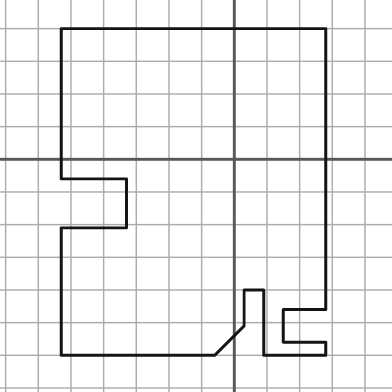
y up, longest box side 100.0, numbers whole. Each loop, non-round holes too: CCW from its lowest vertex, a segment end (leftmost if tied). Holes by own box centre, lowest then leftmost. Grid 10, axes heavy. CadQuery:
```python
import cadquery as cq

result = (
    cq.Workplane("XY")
    .moveTo(-53.0, -60.0)
    .lineTo(-6.0, -60.0)
    .lineTo(3.0, -51.0)
    .lineTo(3.0, -40.0)
    .lineTo(9.0, -40.0)
    .lineTo(9.0, -60.0)
    .lineTo(28.0, -60.0)
    .lineTo(28.0, -56.0)
    .lineTo(15.0, -56.0)
    .lineTo(15.0, -46.0)
    .lineTo(28.0, -46.0)
    .lineTo(28.0, 40.0)
    .lineTo(-53.0, 40.0)
    .lineTo(-53.0, -6.0)
    .lineTo(-33.0, -6.0)
    .lineTo(-33.0, -21.0)
    .lineTo(-53.0, -21.0)
    .close()
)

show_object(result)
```